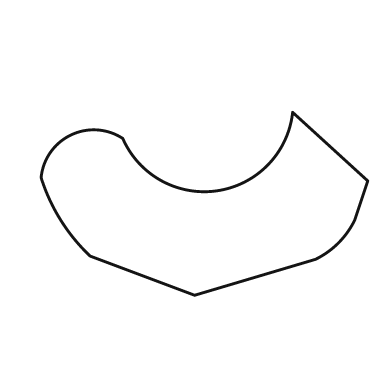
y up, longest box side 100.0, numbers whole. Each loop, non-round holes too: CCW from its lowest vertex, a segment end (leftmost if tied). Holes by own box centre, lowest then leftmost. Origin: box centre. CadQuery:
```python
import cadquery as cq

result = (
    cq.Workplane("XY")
    .moveTo(-3.0, -28.0)
    .lineTo(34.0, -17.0)
    .threePointArc((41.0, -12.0), (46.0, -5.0))
    .lineTo(50.0, 7.0)
    .lineTo(27.0, 28.0)
    .threePointArc((4.0, 4.0), (-25.0, 20.0))
    .threePointArc((-41.0, 21.0), (-50.0, 8.0))
    .threePointArc((-44.0, -5.0), (-35.0, -16.0))
    .close()
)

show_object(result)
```